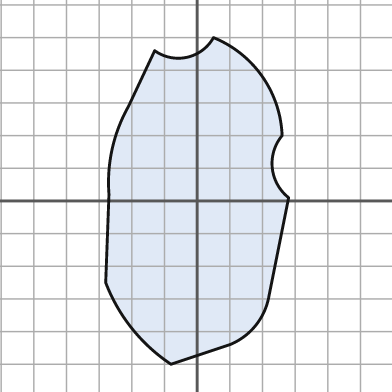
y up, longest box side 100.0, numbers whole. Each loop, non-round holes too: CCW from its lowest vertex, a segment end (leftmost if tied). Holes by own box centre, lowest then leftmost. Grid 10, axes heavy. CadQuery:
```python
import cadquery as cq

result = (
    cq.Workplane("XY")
    .moveTo(-8.0, -50.0)
    .lineTo(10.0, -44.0)
    .threePointArc((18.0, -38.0), (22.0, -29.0))
    .lineTo(28.0, 1.0)
    .threePointArc((23.0, 10.0), (26.0, 20.0))
    .threePointArc((20.0, 38.0), (5.0, 50.0))
    .threePointArc((-3.0, 44.0), (-13.0, 46.0))
    .lineTo(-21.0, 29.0)
    .threePointArc((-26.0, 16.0), (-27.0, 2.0))
    .lineTo(-28.0, -25.0)
    .threePointArc((-20.0, -39.0), (-8.0, -50.0))
    .close()
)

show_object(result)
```